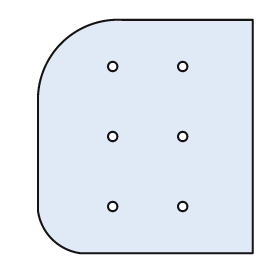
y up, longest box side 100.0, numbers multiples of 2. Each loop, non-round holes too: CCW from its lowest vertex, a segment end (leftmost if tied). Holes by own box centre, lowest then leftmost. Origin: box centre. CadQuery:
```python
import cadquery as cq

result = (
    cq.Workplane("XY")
    .moveTo(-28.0, -50.0)
    .lineTo(46.0, -50.0)
    .lineTo(46.0, 50.0)
    .lineTo(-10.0, 50.0)
    .threePointArc((-36.0, 40.0), (-46.0, 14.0))
    .lineTo(-46.0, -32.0)
    .threePointArc((-40.0, -44.0), (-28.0, -50.0))
    .close()
    .moveTo(-14.0, -30.0)
    .circle(2.0)
    .moveTo(16.0, -30.0)
    .circle(2.0)
    .moveTo(-14.0, 0.0)
    .circle(2.0)
    .moveTo(16.0, 0.0)
    .circle(2.0)
    .moveTo(-14.0, 30.0)
    .circle(2.0)
    .moveTo(16.0, 30.0)
    .circle(2.0)
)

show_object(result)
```